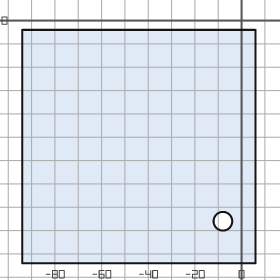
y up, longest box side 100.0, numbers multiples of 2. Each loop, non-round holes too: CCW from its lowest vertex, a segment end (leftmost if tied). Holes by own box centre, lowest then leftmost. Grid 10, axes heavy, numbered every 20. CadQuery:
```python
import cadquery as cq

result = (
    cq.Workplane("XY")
    .moveTo(-94.0, -104.0)
    .lineTo(6.0, -104.0)
    .lineTo(6.0, -4.0)
    .lineTo(-94.0, -4.0)
    .close()
    .moveTo(-8.0, -86.0)
    .circle(4.0)
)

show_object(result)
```